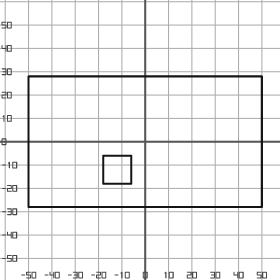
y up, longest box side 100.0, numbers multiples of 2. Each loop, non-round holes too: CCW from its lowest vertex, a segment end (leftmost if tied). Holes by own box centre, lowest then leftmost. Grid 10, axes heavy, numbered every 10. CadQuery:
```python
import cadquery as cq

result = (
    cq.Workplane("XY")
    .moveTo(-50.0, -28.0)
    .lineTo(50.0, -28.0)
    .lineTo(50.0, 28.0)
    .lineTo(-50.0, 28.0)
    .close()
    .moveTo(-18.0, -18.0)
    .lineTo(-6.0, -18.0)
    .lineTo(-6.0, -6.0)
    .lineTo(-18.0, -6.0)
    .close()
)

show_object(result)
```